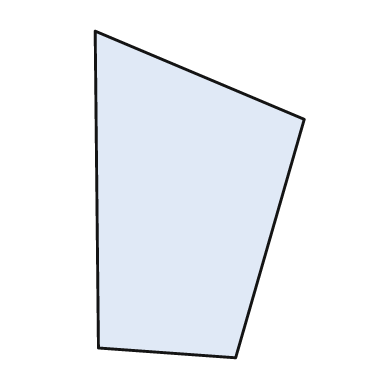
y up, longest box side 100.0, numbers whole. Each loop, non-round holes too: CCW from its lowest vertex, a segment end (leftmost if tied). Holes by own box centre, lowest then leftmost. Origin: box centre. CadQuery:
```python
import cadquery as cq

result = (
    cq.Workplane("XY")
    .moveTo(11.0, -50.0)
    .lineTo(32.0, 23.0)
    .lineTo(-32.0, 50.0)
    .lineTo(-31.0, -47.0)
    .close()
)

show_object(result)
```